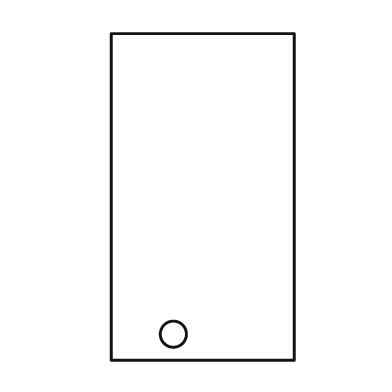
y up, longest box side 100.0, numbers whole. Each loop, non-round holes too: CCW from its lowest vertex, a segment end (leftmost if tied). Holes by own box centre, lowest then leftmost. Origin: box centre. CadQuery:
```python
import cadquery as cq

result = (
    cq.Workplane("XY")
    .moveTo(-28.0, -50.0)
    .lineTo(28.0, -50.0)
    .lineTo(28.0, 50.0)
    .lineTo(-28.0, 50.0)
    .close()
    .moveTo(-9.0, -42.0)
    .circle(4.0)
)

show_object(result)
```